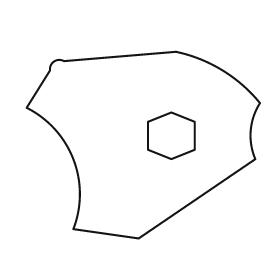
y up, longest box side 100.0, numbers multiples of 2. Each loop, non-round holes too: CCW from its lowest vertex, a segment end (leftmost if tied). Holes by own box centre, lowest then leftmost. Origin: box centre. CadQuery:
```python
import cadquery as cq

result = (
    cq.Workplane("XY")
    .moveTo(-2.0, -40.0)
    .lineTo(48.0, -6.0)
    .threePointArc((46.0, 6.0), (50.0, 18.0))
    .threePointArc((34.0, 32.0), (14.0, 40.0))
    .lineTo(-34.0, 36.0)
    .threePointArc((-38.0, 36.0), (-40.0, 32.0))
    .lineTo(-50.0, 16.0)
    .threePointArc((-30.0, -6.0), (-30.0, -36.0))
    .close()
    .moveTo(12.0, -6.0)
    .lineTo(22.0, -2.0)
    .lineTo(22.0, 10.0)
    .lineTo(12.0, 14.0)
    .lineTo(2.0, 10.0)
    .lineTo(2.0, -2.0)
    .close()
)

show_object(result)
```